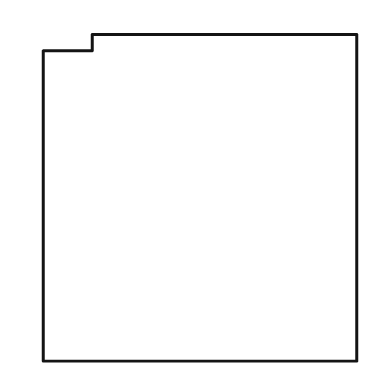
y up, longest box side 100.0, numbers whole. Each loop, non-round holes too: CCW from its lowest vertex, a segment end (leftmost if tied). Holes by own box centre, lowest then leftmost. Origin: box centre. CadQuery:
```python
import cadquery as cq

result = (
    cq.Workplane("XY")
    .moveTo(-48.0, -50.0)
    .lineTo(48.0, -50.0)
    .lineTo(48.0, 50.0)
    .lineTo(-33.0, 50.0)
    .lineTo(-33.0, 45.0)
    .lineTo(-48.0, 45.0)
    .close()
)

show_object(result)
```